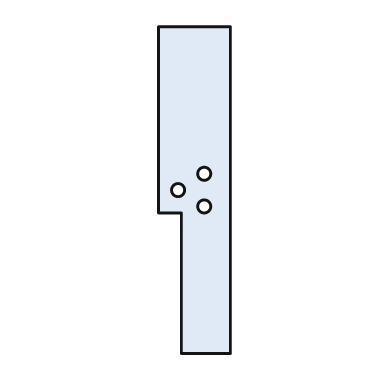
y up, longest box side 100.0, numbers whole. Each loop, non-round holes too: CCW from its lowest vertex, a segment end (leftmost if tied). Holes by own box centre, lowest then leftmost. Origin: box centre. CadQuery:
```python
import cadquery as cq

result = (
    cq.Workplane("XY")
    .moveTo(-4.0, -50.0)
    .lineTo(11.0, -50.0)
    .lineTo(11.0, 50.0)
    .lineTo(-11.0, 50.0)
    .lineTo(-11.0, -7.0)
    .lineTo(-4.0, -7.0)
    .close()
    .moveTo(3.0, -5.0)
    .circle(2.0)
    .moveTo(-5.0, 0.0)
    .circle(2.0)
    .moveTo(3.0, 5.0)
    .circle(2.0)
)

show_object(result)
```